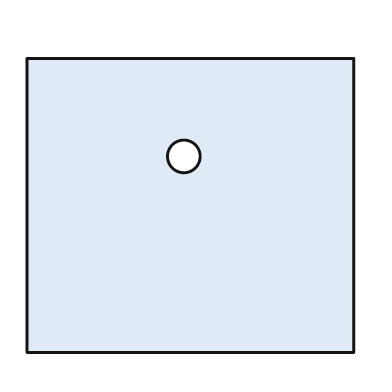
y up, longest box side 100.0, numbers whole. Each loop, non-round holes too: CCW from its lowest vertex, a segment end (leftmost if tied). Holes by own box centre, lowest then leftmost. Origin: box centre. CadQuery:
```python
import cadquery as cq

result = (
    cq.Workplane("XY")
    .moveTo(-50.0, -45.0)
    .lineTo(50.0, -45.0)
    .lineTo(50.0, 45.0)
    .lineTo(-50.0, 45.0)
    .close()
    .moveTo(-2.0, 15.0)
    .circle(5.0)
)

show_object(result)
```